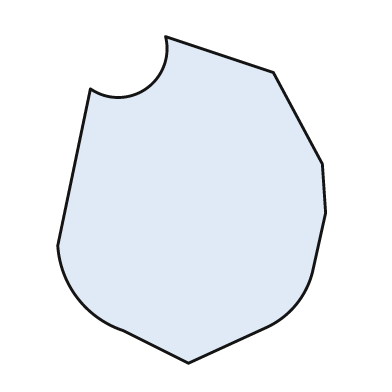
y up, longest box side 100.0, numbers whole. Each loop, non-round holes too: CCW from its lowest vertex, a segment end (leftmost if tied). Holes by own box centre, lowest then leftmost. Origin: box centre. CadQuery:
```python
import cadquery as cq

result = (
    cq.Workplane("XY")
    .moveTo(-1.0, -50.0)
    .lineTo(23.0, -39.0)
    .threePointArc((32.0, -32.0), (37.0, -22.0))
    .lineTo(41.0, -4.0)
    .lineTo(40.0, 11.0)
    .lineTo(25.0, 39.0)
    .lineTo(-8.0, 50.0)
    .threePointArc((-14.0, 34.0), (-31.0, 34.0))
    .lineTo(-41.0, -14.0)
    .threePointArc((-35.0, -30.0), (-21.0, -40.0))
    .close()
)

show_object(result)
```